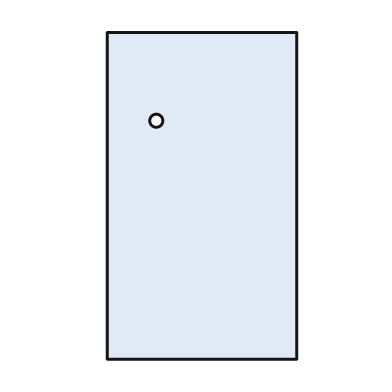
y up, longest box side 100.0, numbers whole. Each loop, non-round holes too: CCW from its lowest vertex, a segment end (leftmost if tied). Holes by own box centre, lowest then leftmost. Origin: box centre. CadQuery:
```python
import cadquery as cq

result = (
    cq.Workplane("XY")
    .moveTo(-29.0, -50.0)
    .lineTo(29.0, -50.0)
    .lineTo(29.0, 50.0)
    .lineTo(-29.0, 50.0)
    .close()
    .moveTo(-14.0, 23.0)
    .circle(2.0)
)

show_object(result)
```